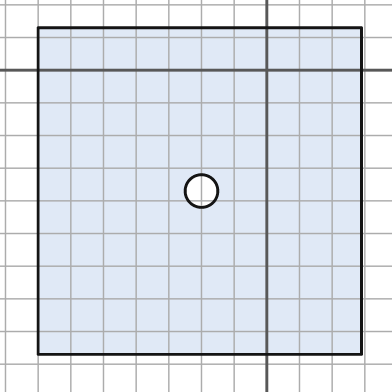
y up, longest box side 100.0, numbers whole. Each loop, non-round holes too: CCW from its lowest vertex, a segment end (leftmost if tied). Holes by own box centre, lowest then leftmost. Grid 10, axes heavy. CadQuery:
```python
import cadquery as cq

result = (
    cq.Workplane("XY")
    .moveTo(-70.0, -87.0)
    .lineTo(29.0, -87.0)
    .lineTo(29.0, 13.0)
    .lineTo(-70.0, 13.0)
    .close()
    .moveTo(-20.0, -37.0)
    .circle(5.0)
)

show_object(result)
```